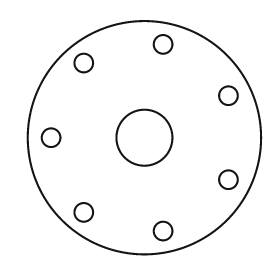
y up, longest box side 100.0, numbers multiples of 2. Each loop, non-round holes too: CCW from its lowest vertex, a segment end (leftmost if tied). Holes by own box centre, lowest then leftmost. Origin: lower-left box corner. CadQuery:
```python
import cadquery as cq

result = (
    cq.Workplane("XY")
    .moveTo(50.0, 50.0)
    .circle(50.0)
    .moveTo(58.0, 10.0)
    .circle(4.0)
    .moveTo(24.0, 18.0)
    .circle(4.0)
    .moveTo(86.0, 32.0)
    .circle(4.0)
    .moveTo(10.0, 50.0)
    .circle(4.0)
    .moveTo(50.0, 50.0)
    .circle(12.0)
    .moveTo(86.0, 68.0)
    .circle(4.0)
    .moveTo(24.0, 82.0)
    .circle(4.0)
    .moveTo(58.0, 90.0)
    .circle(4.0)
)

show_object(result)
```